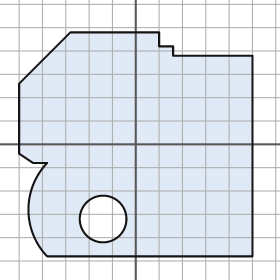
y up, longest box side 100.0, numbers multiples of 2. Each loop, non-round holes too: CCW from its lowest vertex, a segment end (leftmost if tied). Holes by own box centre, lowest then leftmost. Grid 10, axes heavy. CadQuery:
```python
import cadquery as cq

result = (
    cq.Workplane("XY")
    .moveTo(-38.0, -48.0)
    .lineTo(50.0, -48.0)
    .lineTo(50.0, 38.0)
    .lineTo(16.0, 38.0)
    .lineTo(16.0, 42.0)
    .lineTo(10.0, 42.0)
    .lineTo(10.0, 48.0)
    .lineTo(-28.0, 48.0)
    .lineTo(-50.0, 26.0)
    .lineTo(-50.0, -4.0)
    .lineTo(-44.0, -8.0)
    .lineTo(-38.0, -8.0)
    .threePointArc((-46.0, -28.0), (-38.0, -48.0))
    .close()
    .moveTo(-14.0, -32.0)
    .circle(10.0)
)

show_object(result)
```